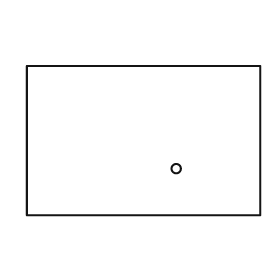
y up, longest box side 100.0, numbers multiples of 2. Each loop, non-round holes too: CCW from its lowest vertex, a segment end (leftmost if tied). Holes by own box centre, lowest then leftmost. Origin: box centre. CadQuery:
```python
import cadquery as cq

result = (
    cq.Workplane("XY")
    .moveTo(-50.0, -32.0)
    .lineTo(50.0, -32.0)
    .lineTo(50.0, 32.0)
    .lineTo(-50.0, 32.0)
    .close()
    .moveTo(14.0, -12.0)
    .circle(2.0)
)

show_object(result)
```